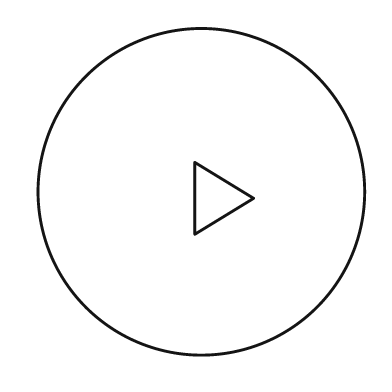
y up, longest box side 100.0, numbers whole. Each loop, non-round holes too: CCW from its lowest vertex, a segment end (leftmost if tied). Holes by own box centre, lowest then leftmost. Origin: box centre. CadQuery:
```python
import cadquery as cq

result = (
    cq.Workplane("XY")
    .moveTo(0.0, 0.0)
    .circle(50.0)
    .moveTo(-2.0, -13.0)
    .lineTo(16.0, -2.0)
    .lineTo(-2.0, 9.0)
    .close()
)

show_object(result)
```